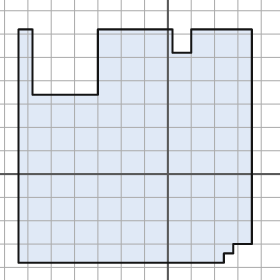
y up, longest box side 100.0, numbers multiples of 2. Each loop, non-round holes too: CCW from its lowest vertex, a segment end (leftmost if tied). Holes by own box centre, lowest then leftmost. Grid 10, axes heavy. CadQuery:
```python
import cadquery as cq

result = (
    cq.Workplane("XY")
    .moveTo(-64.0, -38.0)
    .lineTo(24.0, -38.0)
    .lineTo(24.0, -34.0)
    .lineTo(28.0, -34.0)
    .lineTo(28.0, -30.0)
    .lineTo(36.0, -30.0)
    .lineTo(36.0, 62.0)
    .lineTo(10.0, 62.0)
    .lineTo(10.0, 52.0)
    .lineTo(2.0, 52.0)
    .lineTo(2.0, 62.0)
    .lineTo(-30.0, 62.0)
    .lineTo(-30.0, 34.0)
    .lineTo(-58.0, 34.0)
    .lineTo(-58.0, 62.0)
    .lineTo(-64.0, 62.0)
    .close()
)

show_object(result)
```